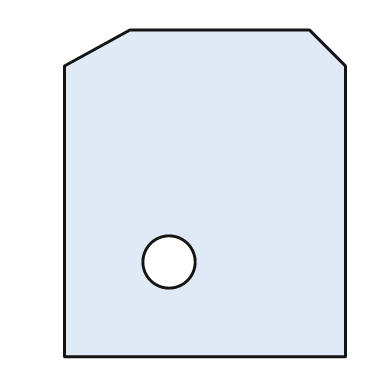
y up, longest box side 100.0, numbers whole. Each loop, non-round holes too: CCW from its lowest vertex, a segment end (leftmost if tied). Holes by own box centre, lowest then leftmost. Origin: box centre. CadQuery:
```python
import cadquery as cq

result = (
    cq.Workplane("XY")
    .moveTo(-43.0, -50.0)
    .lineTo(43.0, -50.0)
    .lineTo(43.0, 39.0)
    .lineTo(32.0, 50.0)
    .lineTo(-23.0, 50.0)
    .lineTo(-43.0, 39.0)
    .close()
    .moveTo(-11.0, -21.0)
    .circle(8.0)
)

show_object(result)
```